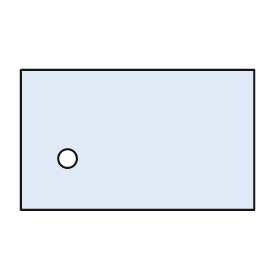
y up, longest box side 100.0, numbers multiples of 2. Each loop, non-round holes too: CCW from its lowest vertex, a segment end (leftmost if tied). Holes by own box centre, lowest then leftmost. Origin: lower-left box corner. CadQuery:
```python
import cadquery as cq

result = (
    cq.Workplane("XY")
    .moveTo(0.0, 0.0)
    .lineTo(100.0, 0.0)
    .lineTo(100.0, 60.0)
    .lineTo(0.0, 60.0)
    .close()
    .moveTo(20.0, 22.0)
    .circle(4.0)
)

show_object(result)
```